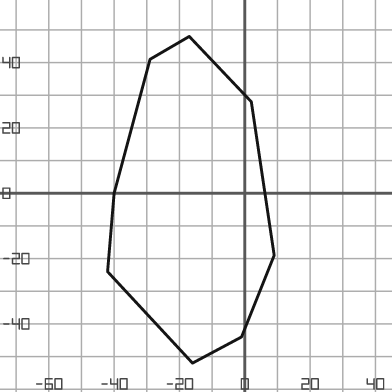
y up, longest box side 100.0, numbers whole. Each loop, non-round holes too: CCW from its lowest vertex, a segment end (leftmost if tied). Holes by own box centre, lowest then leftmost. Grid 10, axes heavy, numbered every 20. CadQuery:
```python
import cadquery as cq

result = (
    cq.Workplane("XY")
    .moveTo(-16.0, -52.0)
    .lineTo(-1.0, -44.0)
    .lineTo(9.0, -19.0)
    .lineTo(2.0, 28.0)
    .lineTo(-17.0, 48.0)
    .lineTo(-29.0, 41.0)
    .lineTo(-40.0, 0.0)
    .lineTo(-42.0, -24.0)
    .close()
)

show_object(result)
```